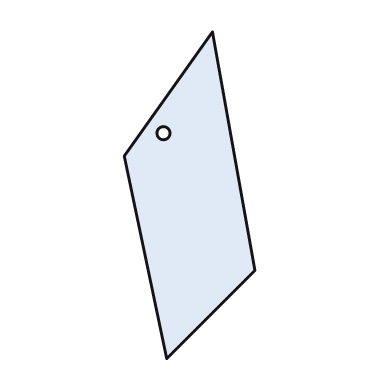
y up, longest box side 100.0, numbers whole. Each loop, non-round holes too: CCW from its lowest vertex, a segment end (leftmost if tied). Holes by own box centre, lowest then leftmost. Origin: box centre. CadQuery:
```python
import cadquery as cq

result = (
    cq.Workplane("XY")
    .moveTo(-7.0, -50.0)
    .lineTo(20.0, -23.0)
    .lineTo(7.0, 50.0)
    .lineTo(-20.0, 12.0)
    .close()
    .moveTo(-8.0, 19.0)
    .circle(2.0)
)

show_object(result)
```